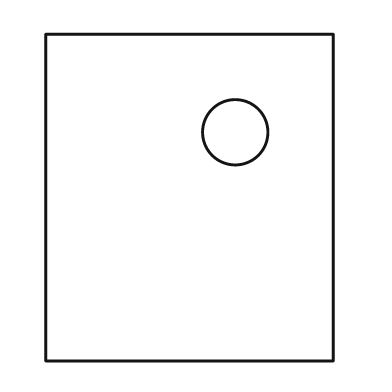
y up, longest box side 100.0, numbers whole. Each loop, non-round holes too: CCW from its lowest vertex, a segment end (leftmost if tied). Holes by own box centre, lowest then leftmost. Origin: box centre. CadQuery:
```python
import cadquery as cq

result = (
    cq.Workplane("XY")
    .moveTo(-44.0, -50.0)
    .lineTo(44.0, -50.0)
    .lineTo(44.0, 50.0)
    .lineTo(-44.0, 50.0)
    .close()
    .moveTo(14.0, 20.0)
    .circle(10.0)
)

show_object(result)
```